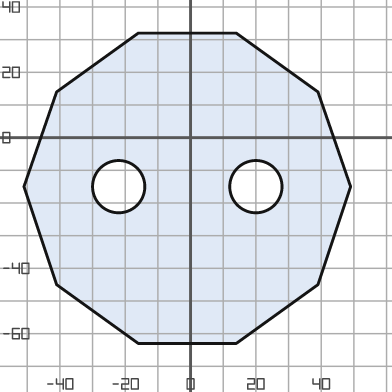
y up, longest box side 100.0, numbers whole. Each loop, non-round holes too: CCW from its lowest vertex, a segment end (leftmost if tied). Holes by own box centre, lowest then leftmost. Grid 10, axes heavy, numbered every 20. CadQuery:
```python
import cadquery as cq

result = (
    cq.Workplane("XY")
    .moveTo(-16.0, -63.0)
    .lineTo(14.0, -63.0)
    .lineTo(39.0, -45.0)
    .lineTo(49.0, -15.0)
    .lineTo(39.0, 14.0)
    .lineTo(14.0, 32.0)
    .lineTo(-16.0, 32.0)
    .lineTo(-41.0, 14.0)
    .lineTo(-51.0, -15.0)
    .lineTo(-41.0, -45.0)
    .close()
    .moveTo(-22.0, -15.0)
    .circle(8.0)
    .moveTo(20.0, -15.0)
    .circle(8.0)
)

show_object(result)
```